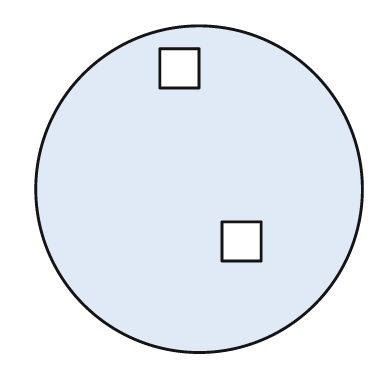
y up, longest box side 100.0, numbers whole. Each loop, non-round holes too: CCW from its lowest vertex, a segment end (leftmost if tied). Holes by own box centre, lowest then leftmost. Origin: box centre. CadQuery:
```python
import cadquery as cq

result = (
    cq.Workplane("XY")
    .moveTo(0.0, 0.0)
    .circle(50.0)
    .moveTo(7.0, -22.0)
    .lineTo(19.0, -22.0)
    .lineTo(19.0, -10.0)
    .lineTo(7.0, -10.0)
    .close()
    .moveTo(-12.0, 31.0)
    .lineTo(0.0, 31.0)
    .lineTo(0.0, 43.0)
    .lineTo(-12.0, 43.0)
    .close()
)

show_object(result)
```